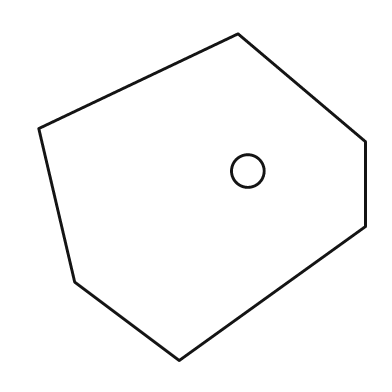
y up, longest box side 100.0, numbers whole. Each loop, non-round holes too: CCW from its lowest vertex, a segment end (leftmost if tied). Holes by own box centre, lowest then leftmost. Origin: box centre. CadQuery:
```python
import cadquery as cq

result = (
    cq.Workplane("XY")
    .moveTo(-7.0, -50.0)
    .lineTo(50.0, -9.0)
    .lineTo(50.0, 17.0)
    .lineTo(11.0, 50.0)
    .lineTo(-50.0, 21.0)
    .lineTo(-39.0, -26.0)
    .close()
    .moveTo(14.0, 8.0)
    .circle(5.0)
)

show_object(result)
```